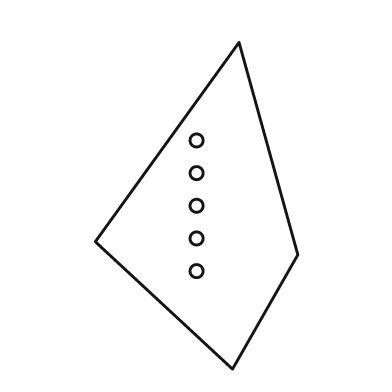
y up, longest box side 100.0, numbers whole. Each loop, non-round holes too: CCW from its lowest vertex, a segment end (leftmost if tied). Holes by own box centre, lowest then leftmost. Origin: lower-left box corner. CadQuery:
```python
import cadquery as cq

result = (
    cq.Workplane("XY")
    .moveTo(42.0, 0.0)
    .lineTo(62.0, 35.0)
    .lineTo(44.0, 100.0)
    .lineTo(0.0, 39.0)
    .close()
    .moveTo(31.0, 30.0)
    .circle(2.0)
    .moveTo(31.0, 40.0)
    .circle(2.0)
    .moveTo(31.0, 50.0)
    .circle(2.0)
    .moveTo(31.0, 60.0)
    .circle(2.0)
    .moveTo(31.0, 70.0)
    .circle(2.0)
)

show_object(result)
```